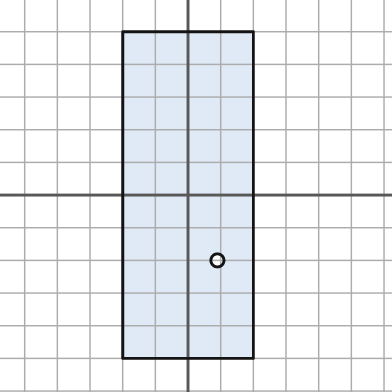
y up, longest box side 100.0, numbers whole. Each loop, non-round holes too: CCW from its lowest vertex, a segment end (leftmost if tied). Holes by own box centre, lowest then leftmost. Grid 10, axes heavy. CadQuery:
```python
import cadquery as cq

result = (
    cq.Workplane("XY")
    .moveTo(-20.0, -50.0)
    .lineTo(20.0, -50.0)
    .lineTo(20.0, 50.0)
    .lineTo(-20.0, 50.0)
    .close()
    .moveTo(9.0, -20.0)
    .circle(2.0)
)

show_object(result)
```